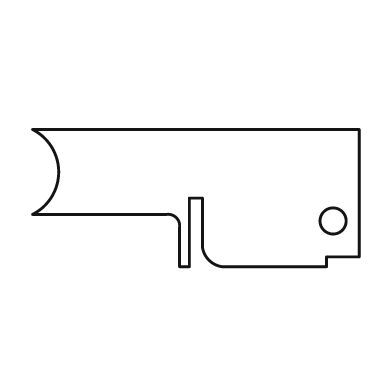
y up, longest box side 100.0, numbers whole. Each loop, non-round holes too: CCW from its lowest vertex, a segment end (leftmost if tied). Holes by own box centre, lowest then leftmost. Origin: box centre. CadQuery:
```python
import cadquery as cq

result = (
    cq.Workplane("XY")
    .moveTo(-5.0, -21.0)
    .lineTo(-2.0, -21.0)
    .lineTo(-2.0, 0.0)
    .lineTo(2.0, 0.0)
    .lineTo(2.0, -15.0)
    .threePointArc((4.0, -19.0), (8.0, -21.0))
    .lineTo(40.0, -21.0)
    .lineTo(40.0, -18.0)
    .lineTo(50.0, -18.0)
    .lineTo(50.0, 21.0)
    .lineTo(-50.0, 21.0)
    .threePointArc((-42.0, 8.0), (-50.0, -5.0))
    .lineTo(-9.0, -5.0)
    .threePointArc((-6.0, -6.0), (-5.0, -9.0))
    .close()
    .moveTo(42.0, -7.0)
    .circle(4.0)
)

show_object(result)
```